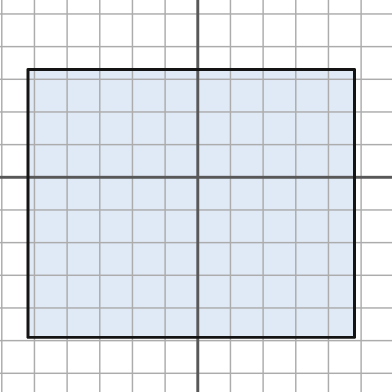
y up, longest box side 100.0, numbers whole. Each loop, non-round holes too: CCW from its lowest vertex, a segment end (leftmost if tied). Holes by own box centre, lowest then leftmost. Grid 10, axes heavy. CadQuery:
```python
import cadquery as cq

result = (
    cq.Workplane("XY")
    .moveTo(-52.0, -49.0)
    .lineTo(48.0, -49.0)
    .lineTo(48.0, 33.0)
    .lineTo(-52.0, 33.0)
    .close()
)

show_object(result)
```